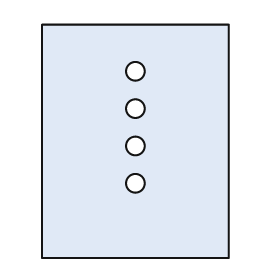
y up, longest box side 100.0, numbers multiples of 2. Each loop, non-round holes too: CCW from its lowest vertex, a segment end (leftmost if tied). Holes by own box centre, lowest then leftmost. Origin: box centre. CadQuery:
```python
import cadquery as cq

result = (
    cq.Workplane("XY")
    .moveTo(-40.0, -50.0)
    .lineTo(40.0, -50.0)
    .lineTo(40.0, 50.0)
    .lineTo(-40.0, 50.0)
    .close()
    .moveTo(0.0, -18.0)
    .circle(4.0)
    .moveTo(0.0, -2.0)
    .circle(4.0)
    .moveTo(0.0, 14.0)
    .circle(4.0)
    .moveTo(0.0, 30.0)
    .circle(4.0)
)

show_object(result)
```